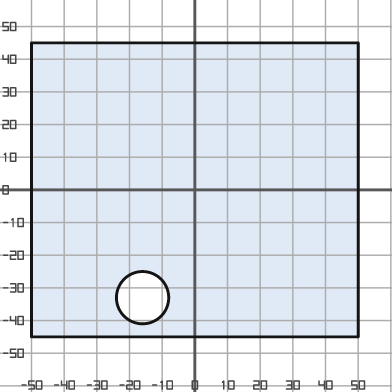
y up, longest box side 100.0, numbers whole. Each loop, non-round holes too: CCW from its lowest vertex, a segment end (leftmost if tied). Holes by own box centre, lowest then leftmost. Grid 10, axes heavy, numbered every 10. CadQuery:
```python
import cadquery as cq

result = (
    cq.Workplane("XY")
    .moveTo(-50.0, -45.0)
    .lineTo(50.0, -45.0)
    .lineTo(50.0, 45.0)
    .lineTo(-50.0, 45.0)
    .close()
    .moveTo(-16.0, -33.0)
    .circle(8.0)
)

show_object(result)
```